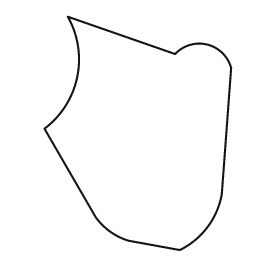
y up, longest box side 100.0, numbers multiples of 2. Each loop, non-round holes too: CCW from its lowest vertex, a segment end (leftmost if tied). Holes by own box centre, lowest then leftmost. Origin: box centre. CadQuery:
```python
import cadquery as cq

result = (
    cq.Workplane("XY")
    .moveTo(18.0, -50.0)
    .threePointArc((30.0, -40.0), (36.0, -26.0))
    .lineTo(40.0, 28.0)
    .threePointArc((30.0, 38.0), (16.0, 34.0))
    .lineTo(-30.0, 50.0)
    .threePointArc((-26.0, 24.0), (-40.0, 2.0))
    .lineTo(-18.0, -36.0)
    .threePointArc((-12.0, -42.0), (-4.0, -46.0))
    .close()
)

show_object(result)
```